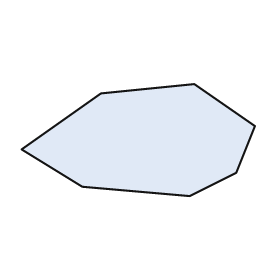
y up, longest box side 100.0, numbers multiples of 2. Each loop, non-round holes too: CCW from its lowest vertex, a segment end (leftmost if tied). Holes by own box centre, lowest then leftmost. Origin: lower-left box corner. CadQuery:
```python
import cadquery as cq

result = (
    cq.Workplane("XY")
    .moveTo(72.0, 0.0)
    .lineTo(92.0, 10.0)
    .lineTo(100.0, 30.0)
    .lineTo(74.0, 48.0)
    .lineTo(34.0, 44.0)
    .lineTo(0.0, 20.0)
    .lineTo(26.0, 4.0)
    .close()
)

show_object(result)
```